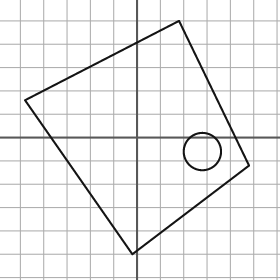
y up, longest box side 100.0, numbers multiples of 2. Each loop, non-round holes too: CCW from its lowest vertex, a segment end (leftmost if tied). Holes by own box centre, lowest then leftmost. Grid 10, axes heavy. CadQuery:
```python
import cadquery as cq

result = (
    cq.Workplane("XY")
    .moveTo(-2.0, -50.0)
    .lineTo(48.0, -12.0)
    .lineTo(18.0, 50.0)
    .lineTo(-48.0, 16.0)
    .close()
    .moveTo(28.0, -6.0)
    .circle(8.0)
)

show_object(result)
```